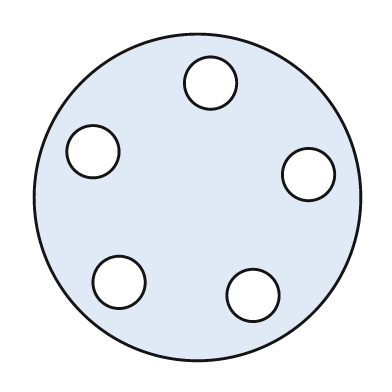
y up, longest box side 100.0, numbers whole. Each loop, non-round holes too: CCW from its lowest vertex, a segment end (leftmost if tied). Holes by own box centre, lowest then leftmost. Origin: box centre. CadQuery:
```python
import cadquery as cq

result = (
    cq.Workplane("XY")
    .moveTo(0.0, 0.0)
    .circle(50.0)
    .moveTo(17.0, -30.0)
    .circle(8.0)
    .moveTo(-24.0, -26.0)
    .circle(8.0)
    .moveTo(34.0, 7.0)
    .circle(8.0)
    .moveTo(-32.0, 14.0)
    .circle(8.0)
    .moveTo(4.0, 35.0)
    .circle(8.0)
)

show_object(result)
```